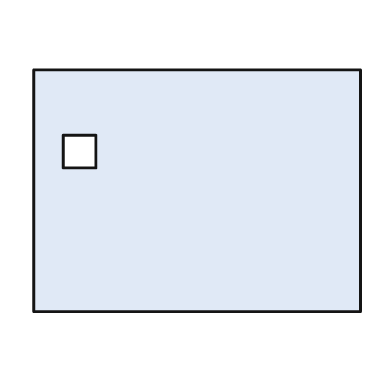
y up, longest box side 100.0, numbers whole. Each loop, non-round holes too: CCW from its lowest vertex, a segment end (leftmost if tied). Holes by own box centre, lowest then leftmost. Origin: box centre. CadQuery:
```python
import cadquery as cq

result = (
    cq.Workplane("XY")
    .moveTo(-50.0, -37.0)
    .lineTo(50.0, -37.0)
    .lineTo(50.0, 37.0)
    .lineTo(-50.0, 37.0)
    .close()
    .moveTo(-41.0, 7.0)
    .lineTo(-31.0, 7.0)
    .lineTo(-31.0, 17.0)
    .lineTo(-41.0, 17.0)
    .close()
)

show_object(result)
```